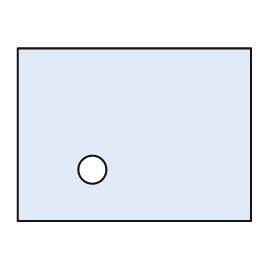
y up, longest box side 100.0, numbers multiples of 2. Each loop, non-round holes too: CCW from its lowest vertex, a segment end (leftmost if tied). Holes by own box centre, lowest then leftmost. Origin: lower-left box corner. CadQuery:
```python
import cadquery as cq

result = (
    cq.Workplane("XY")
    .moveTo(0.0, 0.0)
    .lineTo(100.0, 0.0)
    .lineTo(100.0, 74.0)
    .lineTo(0.0, 74.0)
    .close()
    .moveTo(32.0, 22.0)
    .circle(6.0)
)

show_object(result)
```